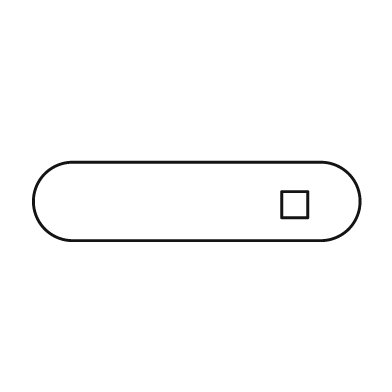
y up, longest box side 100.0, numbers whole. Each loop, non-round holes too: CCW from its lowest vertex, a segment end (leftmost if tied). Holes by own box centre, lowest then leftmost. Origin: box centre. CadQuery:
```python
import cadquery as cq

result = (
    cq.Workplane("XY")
    .moveTo(-38.0, -12.0)
    .lineTo(38.0, -12.0)
    .threePointArc((50.0, 0.0), (38.0, 12.0))
    .lineTo(-38.0, 12.0)
    .threePointArc((-50.0, 0.0), (-38.0, -12.0))
    .close()
    .moveTo(26.0, -5.0)
    .lineTo(34.0, -5.0)
    .lineTo(34.0, 3.0)
    .lineTo(26.0, 3.0)
    .close()
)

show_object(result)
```